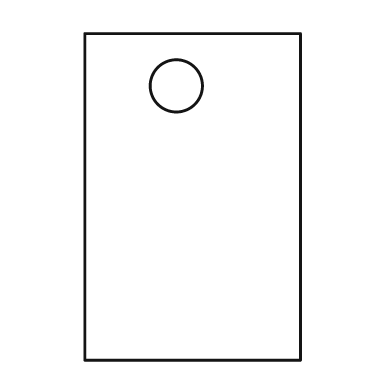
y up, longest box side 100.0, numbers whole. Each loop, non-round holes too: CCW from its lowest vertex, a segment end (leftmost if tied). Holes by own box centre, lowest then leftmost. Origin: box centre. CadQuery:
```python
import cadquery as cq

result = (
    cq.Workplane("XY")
    .moveTo(-33.0, -50.0)
    .lineTo(33.0, -50.0)
    .lineTo(33.0, 50.0)
    .lineTo(-33.0, 50.0)
    .close()
    .moveTo(-5.0, 34.0)
    .circle(8.0)
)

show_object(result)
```